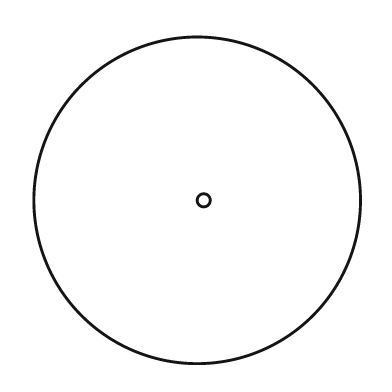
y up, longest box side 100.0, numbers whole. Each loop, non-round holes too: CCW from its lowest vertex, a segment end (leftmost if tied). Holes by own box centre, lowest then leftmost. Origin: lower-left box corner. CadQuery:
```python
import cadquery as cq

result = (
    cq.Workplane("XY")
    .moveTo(50.0, 50.0)
    .circle(50.0)
    .moveTo(52.0, 50.0)
    .circle(2.0)
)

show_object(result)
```